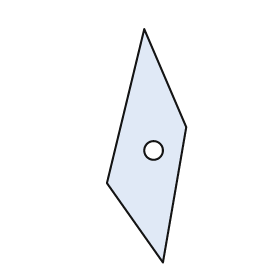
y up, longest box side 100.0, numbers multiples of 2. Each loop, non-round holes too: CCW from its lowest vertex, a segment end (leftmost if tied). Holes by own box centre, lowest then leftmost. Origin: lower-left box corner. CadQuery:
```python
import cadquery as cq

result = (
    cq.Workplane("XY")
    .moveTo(24.0, 0.0)
    .lineTo(34.0, 58.0)
    .lineTo(16.0, 100.0)
    .lineTo(0.0, 34.0)
    .close()
    .moveTo(20.0, 48.0)
    .circle(4.0)
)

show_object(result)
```